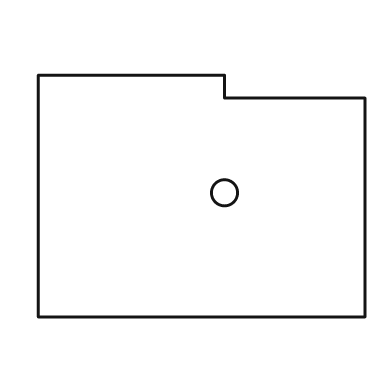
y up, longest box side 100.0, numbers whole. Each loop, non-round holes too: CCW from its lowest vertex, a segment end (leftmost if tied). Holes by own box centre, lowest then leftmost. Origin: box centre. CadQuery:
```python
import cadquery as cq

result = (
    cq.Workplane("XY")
    .moveTo(-50.0, -37.0)
    .lineTo(50.0, -37.0)
    .lineTo(50.0, 30.0)
    .lineTo(7.0, 30.0)
    .lineTo(7.0, 37.0)
    .lineTo(-50.0, 37.0)
    .close()
    .moveTo(7.0, 1.0)
    .circle(4.0)
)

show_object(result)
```